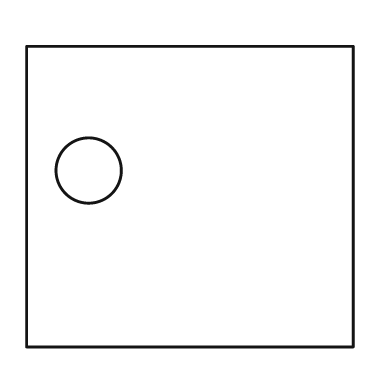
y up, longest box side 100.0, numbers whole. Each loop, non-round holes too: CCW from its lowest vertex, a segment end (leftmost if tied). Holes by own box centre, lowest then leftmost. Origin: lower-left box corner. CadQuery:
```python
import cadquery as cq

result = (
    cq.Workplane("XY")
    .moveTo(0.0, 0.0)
    .lineTo(100.0, 0.0)
    .lineTo(100.0, 92.0)
    .lineTo(0.0, 92.0)
    .close()
    .moveTo(19.0, 54.0)
    .circle(10.0)
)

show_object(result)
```